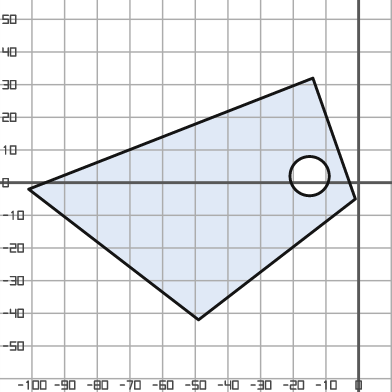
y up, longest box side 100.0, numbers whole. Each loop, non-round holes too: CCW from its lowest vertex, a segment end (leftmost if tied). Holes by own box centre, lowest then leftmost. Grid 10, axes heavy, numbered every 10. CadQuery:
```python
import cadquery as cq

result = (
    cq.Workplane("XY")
    .moveTo(-49.0, -42.0)
    .lineTo(-1.0, -5.0)
    .lineTo(-14.0, 32.0)
    .lineTo(-101.0, -2.0)
    .close()
    .moveTo(-15.0, 2.0)
    .circle(6.0)
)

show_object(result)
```